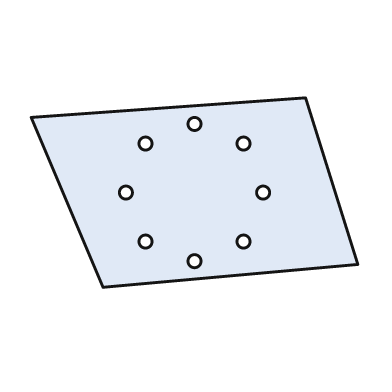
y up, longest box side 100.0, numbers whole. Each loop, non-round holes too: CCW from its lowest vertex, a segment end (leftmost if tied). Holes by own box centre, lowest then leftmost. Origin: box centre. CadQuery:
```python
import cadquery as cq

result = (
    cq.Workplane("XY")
    .moveTo(-28.0, -29.0)
    .lineTo(50.0, -22.0)
    .lineTo(34.0, 29.0)
    .lineTo(-50.0, 23.0)
    .close()
    .moveTo(0.0, -21.0)
    .circle(2.0)
    .moveTo(-15.0, -15.0)
    .circle(2.0)
    .moveTo(15.0, -15.0)
    .circle(2.0)
    .moveTo(-21.0, 0.0)
    .circle(2.0)
    .moveTo(21.0, 0.0)
    .circle(2.0)
    .moveTo(-15.0, 15.0)
    .circle(2.0)
    .moveTo(15.0, 15.0)
    .circle(2.0)
    .moveTo(0.0, 21.0)
    .circle(2.0)
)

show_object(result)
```